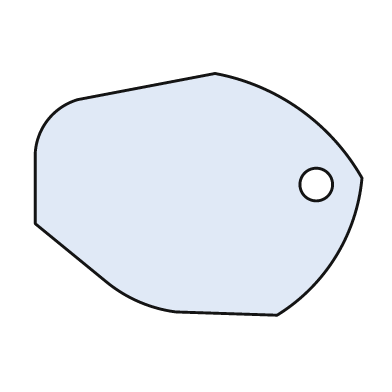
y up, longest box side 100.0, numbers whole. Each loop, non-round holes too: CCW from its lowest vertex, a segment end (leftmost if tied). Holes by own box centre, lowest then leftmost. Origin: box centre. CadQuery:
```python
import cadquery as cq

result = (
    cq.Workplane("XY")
    .moveTo(24.0, -37.0)
    .threePointArc((42.0, -19.0), (50.0, 5.0))
    .threePointArc((31.0, 26.0), (5.0, 37.0))
    .lineTo(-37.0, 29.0)
    .threePointArc((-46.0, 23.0), (-50.0, 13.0))
    .lineTo(-50.0, -9.0)
    .lineTo(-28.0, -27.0)
    .threePointArc((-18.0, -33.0), (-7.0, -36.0))
    .close()
    .moveTo(36.0, 3.0)
    .circle(5.0)
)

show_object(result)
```